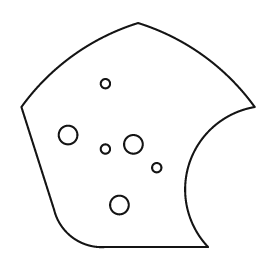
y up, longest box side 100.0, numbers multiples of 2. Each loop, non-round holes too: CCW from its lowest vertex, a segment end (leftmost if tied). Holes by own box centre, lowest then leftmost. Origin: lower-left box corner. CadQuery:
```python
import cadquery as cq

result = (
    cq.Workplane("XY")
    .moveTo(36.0, 0.0)
    .lineTo(80.0, 0.0)
    .threePointArc((72.0, 36.0), (100.0, 60.0))
    .threePointArc((78.0, 82.0), (50.0, 96.0))
    .threePointArc((22.0, 82.0), (0.0, 60.0))
    .lineTo(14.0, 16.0)
    .threePointArc((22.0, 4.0), (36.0, 0.0))
    .close()
    .moveTo(42.0, 18.0)
    .circle(4.0)
    .moveTo(58.0, 34.0)
    .circle(2.0)
    .moveTo(36.0, 42.0)
    .circle(2.0)
    .moveTo(48.0, 44.0)
    .circle(4.0)
    .moveTo(20.0, 48.0)
    .circle(4.0)
    .moveTo(36.0, 70.0)
    .circle(2.0)
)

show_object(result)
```